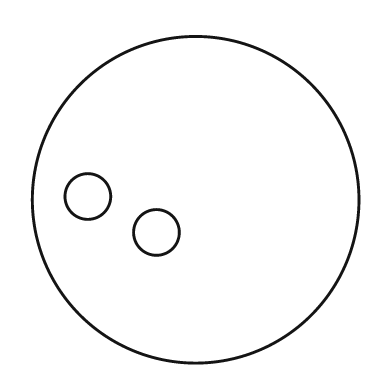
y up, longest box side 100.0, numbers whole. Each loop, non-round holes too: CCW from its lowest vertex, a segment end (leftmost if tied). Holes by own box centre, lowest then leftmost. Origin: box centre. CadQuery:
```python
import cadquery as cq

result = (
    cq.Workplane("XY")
    .moveTo(0.0, 0.0)
    .circle(50.0)
    .moveTo(-12.0, -10.0)
    .circle(7.0)
    .moveTo(-33.0, 1.0)
    .circle(7.0)
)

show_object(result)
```